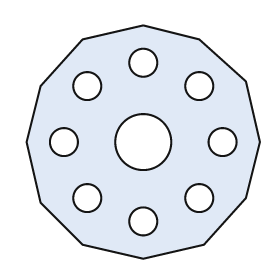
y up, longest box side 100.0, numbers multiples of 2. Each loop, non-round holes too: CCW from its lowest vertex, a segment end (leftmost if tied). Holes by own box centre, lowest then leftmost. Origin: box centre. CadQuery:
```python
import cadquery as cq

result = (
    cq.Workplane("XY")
    .moveTo(0.0, -50.0)
    .lineTo(26.0, -44.0)
    .lineTo(44.0, -24.0)
    .lineTo(50.0, 0.0)
    .lineTo(44.0, 26.0)
    .lineTo(24.0, 44.0)
    .lineTo(0.0, 50.0)
    .lineTo(-26.0, 44.0)
    .lineTo(-44.0, 24.0)
    .lineTo(-50.0, 0.0)
    .lineTo(-44.0, -26.0)
    .lineTo(-26.0, -44.0)
    .close()
    .moveTo(0.0, -34.0)
    .circle(6.0)
    .moveTo(-24.0, -24.0)
    .circle(6.0)
    .moveTo(24.0, -24.0)
    .circle(6.0)
    .moveTo(-34.0, 0.0)
    .circle(6.0)
    .moveTo(0.0, 0.0)
    .circle(12.0)
    .moveTo(34.0, 0.0)
    .circle(6.0)
    .moveTo(-24.0, 24.0)
    .circle(6.0)
    .moveTo(24.0, 24.0)
    .circle(6.0)
    .moveTo(0.0, 34.0)
    .circle(6.0)
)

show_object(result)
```